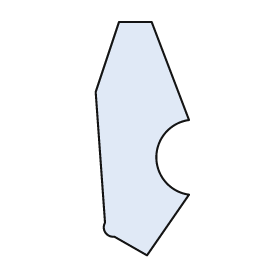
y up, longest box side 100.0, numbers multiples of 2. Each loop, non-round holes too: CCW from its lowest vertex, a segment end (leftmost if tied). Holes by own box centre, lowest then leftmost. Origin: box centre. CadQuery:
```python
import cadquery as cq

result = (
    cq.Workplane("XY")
    .moveTo(2.0, -50.0)
    .lineTo(20.0, -24.0)
    .threePointArc((6.0, -8.0), (20.0, 8.0))
    .lineTo(4.0, 50.0)
    .lineTo(-10.0, 50.0)
    .lineTo(-20.0, 20.0)
    .lineTo(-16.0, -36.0)
    .threePointArc((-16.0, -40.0), (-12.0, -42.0))
    .close()
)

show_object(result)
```